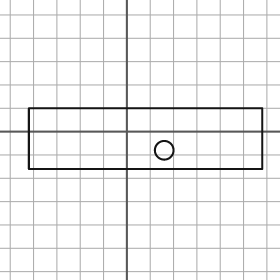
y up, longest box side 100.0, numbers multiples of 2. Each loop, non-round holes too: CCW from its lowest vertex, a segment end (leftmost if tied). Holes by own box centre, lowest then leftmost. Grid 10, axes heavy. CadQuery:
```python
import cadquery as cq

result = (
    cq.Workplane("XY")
    .moveTo(-42.0, -16.0)
    .lineTo(58.0, -16.0)
    .lineTo(58.0, 10.0)
    .lineTo(-42.0, 10.0)
    .close()
    .moveTo(16.0, -8.0)
    .circle(4.0)
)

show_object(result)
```